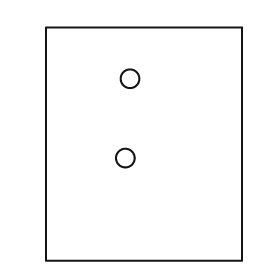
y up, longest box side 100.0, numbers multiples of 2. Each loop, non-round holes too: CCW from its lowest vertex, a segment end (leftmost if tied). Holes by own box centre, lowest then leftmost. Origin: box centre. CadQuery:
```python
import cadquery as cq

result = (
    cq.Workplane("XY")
    .moveTo(-42.0, -50.0)
    .lineTo(42.0, -50.0)
    .lineTo(42.0, 50.0)
    .lineTo(-42.0, 50.0)
    .close()
    .moveTo(-8.0, -6.0)
    .circle(4.0)
    .moveTo(-6.0, 28.0)
    .circle(4.0)
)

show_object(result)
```